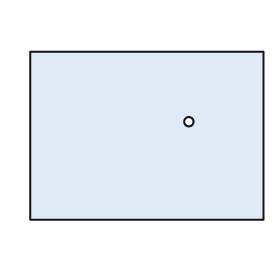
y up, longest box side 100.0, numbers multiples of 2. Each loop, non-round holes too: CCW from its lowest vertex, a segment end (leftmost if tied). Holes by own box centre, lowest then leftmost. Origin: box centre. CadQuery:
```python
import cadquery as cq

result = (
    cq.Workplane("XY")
    .moveTo(-50.0, -36.0)
    .lineTo(50.0, -36.0)
    .lineTo(50.0, 36.0)
    .lineTo(-50.0, 36.0)
    .close()
    .moveTo(18.0, 6.0)
    .circle(2.0)
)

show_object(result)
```